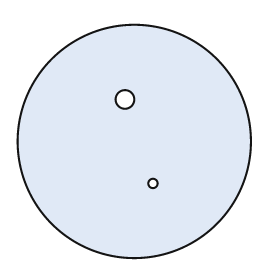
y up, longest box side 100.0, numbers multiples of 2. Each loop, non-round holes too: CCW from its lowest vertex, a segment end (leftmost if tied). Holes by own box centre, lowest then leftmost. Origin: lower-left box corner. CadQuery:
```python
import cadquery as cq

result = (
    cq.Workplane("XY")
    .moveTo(50.0, 50.0)
    .circle(50.0)
    .moveTo(58.0, 32.0)
    .circle(2.0)
    .moveTo(46.0, 68.0)
    .circle(4.0)
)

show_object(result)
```